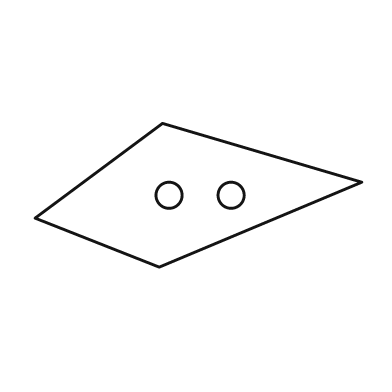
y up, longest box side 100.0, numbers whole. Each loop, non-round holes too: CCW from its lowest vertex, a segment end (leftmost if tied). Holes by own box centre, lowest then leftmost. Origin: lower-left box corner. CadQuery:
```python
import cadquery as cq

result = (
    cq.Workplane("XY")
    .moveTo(38.0, 0.0)
    .lineTo(100.0, 26.0)
    .lineTo(39.0, 44.0)
    .lineTo(0.0, 15.0)
    .close()
    .moveTo(41.0, 22.0)
    .circle(4.0)
    .moveTo(60.0, 22.0)
    .circle(4.0)
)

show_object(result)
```